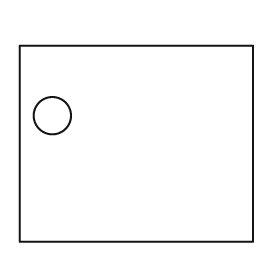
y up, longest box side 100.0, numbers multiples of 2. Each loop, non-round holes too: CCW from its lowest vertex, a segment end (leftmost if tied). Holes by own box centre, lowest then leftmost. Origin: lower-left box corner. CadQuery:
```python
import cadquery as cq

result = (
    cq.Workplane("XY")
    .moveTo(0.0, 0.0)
    .lineTo(100.0, 0.0)
    .lineTo(100.0, 84.0)
    .lineTo(0.0, 84.0)
    .close()
    .moveTo(14.0, 54.0)
    .circle(8.0)
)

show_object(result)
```